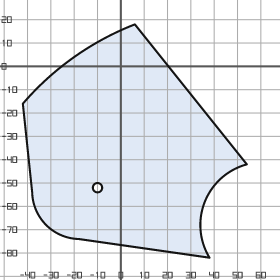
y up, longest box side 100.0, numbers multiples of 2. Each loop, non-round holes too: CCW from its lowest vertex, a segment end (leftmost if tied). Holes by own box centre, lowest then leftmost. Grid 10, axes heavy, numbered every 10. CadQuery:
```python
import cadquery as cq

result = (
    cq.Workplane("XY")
    .moveTo(38.0, -82.0)
    .threePointArc((36.0, -58.0), (54.0, -42.0))
    .lineTo(6.0, 18.0)
    .threePointArc((-20.0, 4.0), (-42.0, -16.0))
    .lineTo(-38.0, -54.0)
    .threePointArc((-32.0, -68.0), (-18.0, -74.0))
    .close()
    .moveTo(-10.0, -52.0)
    .circle(2.0)
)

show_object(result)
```